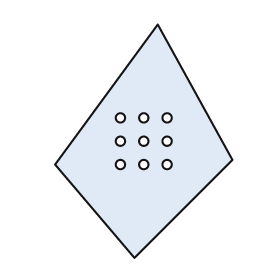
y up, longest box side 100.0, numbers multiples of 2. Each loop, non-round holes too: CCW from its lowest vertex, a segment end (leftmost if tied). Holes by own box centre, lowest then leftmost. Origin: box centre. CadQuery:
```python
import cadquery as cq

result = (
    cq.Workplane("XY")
    .moveTo(-4.0, -50.0)
    .lineTo(38.0, -8.0)
    .lineTo(6.0, 50.0)
    .lineTo(-38.0, -10.0)
    .close()
    .moveTo(-10.0, -10.0)
    .circle(2.0)
    .moveTo(0.0, -10.0)
    .circle(2.0)
    .moveTo(10.0, -10.0)
    .circle(2.0)
    .moveTo(-10.0, 0.0)
    .circle(2.0)
    .moveTo(0.0, 0.0)
    .circle(2.0)
    .moveTo(10.0, 0.0)
    .circle(2.0)
    .moveTo(-10.0, 10.0)
    .circle(2.0)
    .moveTo(0.0, 10.0)
    .circle(2.0)
    .moveTo(10.0, 10.0)
    .circle(2.0)
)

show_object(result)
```